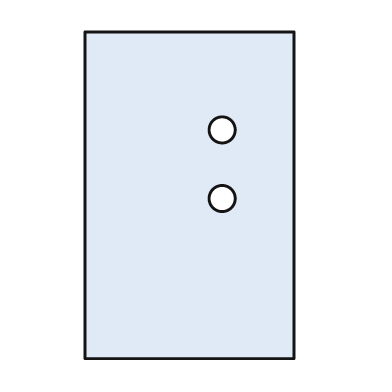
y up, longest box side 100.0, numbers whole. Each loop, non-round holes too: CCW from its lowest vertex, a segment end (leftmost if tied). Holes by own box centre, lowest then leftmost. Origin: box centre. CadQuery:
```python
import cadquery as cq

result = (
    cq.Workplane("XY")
    .moveTo(-32.0, -50.0)
    .lineTo(32.0, -50.0)
    .lineTo(32.0, 50.0)
    .lineTo(-32.0, 50.0)
    .close()
    .moveTo(10.0, -1.0)
    .circle(4.0)
    .moveTo(10.0, 20.0)
    .circle(4.0)
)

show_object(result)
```